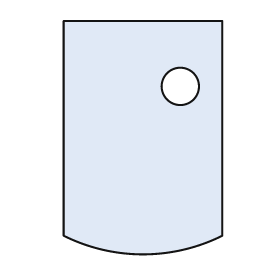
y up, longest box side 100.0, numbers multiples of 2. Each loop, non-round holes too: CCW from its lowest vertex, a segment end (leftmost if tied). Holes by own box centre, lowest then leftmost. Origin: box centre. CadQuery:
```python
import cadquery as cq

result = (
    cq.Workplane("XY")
    .moveTo(-34.0, -42.0)
    .threePointArc((0.0, -50.0), (34.0, -42.0))
    .lineTo(34.0, 50.0)
    .lineTo(-34.0, 50.0)
    .close()
    .moveTo(16.0, 22.0)
    .circle(8.0)
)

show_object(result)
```